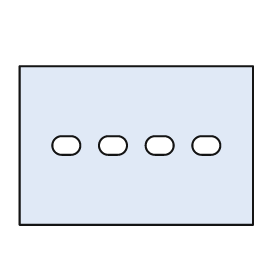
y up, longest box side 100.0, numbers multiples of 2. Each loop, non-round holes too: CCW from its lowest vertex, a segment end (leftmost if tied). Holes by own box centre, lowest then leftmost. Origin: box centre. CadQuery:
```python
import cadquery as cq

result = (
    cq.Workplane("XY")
    .moveTo(-50.0, -34.0)
    .lineTo(50.0, -34.0)
    .lineTo(50.0, 34.0)
    .lineTo(-50.0, 34.0)
    .close()
    .moveTo(-32.0, -4.0)
    .lineTo(-28.0, -4.0)
    .threePointArc((-24.0, 0.0), (-28.0, 4.0))
    .lineTo(-32.0, 4.0)
    .threePointArc((-36.0, 0.0), (-32.0, -4.0))
    .close()
    .moveTo(-12.0, -4.0)
    .lineTo(-8.0, -4.0)
    .threePointArc((-4.0, 0.0), (-8.0, 4.0))
    .lineTo(-12.0, 4.0)
    .threePointArc((-16.0, 0.0), (-12.0, -4.0))
    .close()
    .moveTo(8.0, -4.0)
    .lineTo(12.0, -4.0)
    .threePointArc((16.0, 0.0), (12.0, 4.0))
    .lineTo(8.0, 4.0)
    .threePointArc((4.0, 0.0), (8.0, -4.0))
    .close()
    .moveTo(28.0, -4.0)
    .lineTo(32.0, -4.0)
    .threePointArc((36.0, 0.0), (32.0, 4.0))
    .lineTo(28.0, 4.0)
    .threePointArc((24.0, 0.0), (28.0, -4.0))
    .close()
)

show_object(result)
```